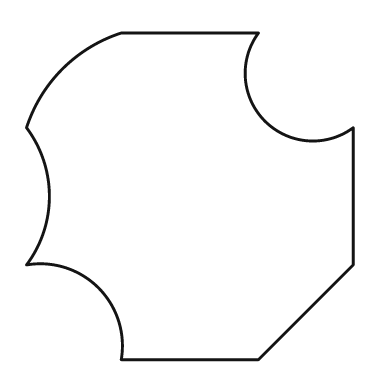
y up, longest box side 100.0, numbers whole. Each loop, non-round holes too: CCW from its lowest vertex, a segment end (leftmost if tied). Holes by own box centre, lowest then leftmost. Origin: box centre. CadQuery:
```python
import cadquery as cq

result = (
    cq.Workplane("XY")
    .moveTo(-21.0, -50.0)
    .lineTo(21.0, -50.0)
    .lineTo(50.0, -21.0)
    .lineTo(50.0, 21.0)
    .threePointArc((23.0, 23.0), (21.0, 50.0))
    .lineTo(-21.0, 50.0)
    .threePointArc((-39.0, 39.0), (-50.0, 21.0))
    .threePointArc((-43.0, 0.0), (-50.0, -21.0))
    .threePointArc((-28.0, -28.0), (-21.0, -50.0))
    .close()
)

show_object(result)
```